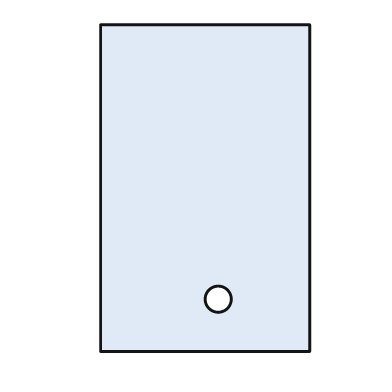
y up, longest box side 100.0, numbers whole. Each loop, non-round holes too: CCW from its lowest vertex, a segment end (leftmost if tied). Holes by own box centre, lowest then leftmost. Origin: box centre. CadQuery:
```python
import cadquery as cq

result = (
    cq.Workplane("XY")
    .moveTo(-32.0, -50.0)
    .lineTo(32.0, -50.0)
    .lineTo(32.0, 50.0)
    .lineTo(-32.0, 50.0)
    .close()
    .moveTo(4.0, -34.0)
    .circle(4.0)
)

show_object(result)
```